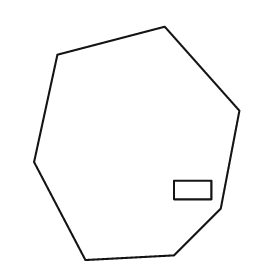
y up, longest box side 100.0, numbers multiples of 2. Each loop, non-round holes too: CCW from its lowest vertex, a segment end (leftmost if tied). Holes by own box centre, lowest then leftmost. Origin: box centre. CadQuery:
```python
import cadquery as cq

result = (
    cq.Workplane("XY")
    .moveTo(-22.0, -50.0)
    .lineTo(16.0, -48.0)
    .lineTo(36.0, -28.0)
    .lineTo(44.0, 14.0)
    .lineTo(12.0, 50.0)
    .lineTo(-34.0, 38.0)
    .lineTo(-44.0, -8.0)
    .close()
    .moveTo(16.0, -24.0)
    .lineTo(32.0, -24.0)
    .lineTo(32.0, -16.0)
    .lineTo(16.0, -16.0)
    .close()
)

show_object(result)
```